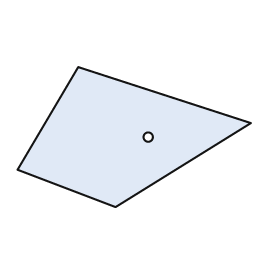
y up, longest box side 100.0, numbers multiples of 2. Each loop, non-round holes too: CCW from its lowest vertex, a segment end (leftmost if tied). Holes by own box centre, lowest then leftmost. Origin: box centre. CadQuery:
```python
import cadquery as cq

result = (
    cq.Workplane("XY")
    .moveTo(-8.0, -30.0)
    .lineTo(50.0, 6.0)
    .lineTo(-24.0, 30.0)
    .lineTo(-50.0, -14.0)
    .close()
    .moveTo(6.0, 0.0)
    .circle(2.0)
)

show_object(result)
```